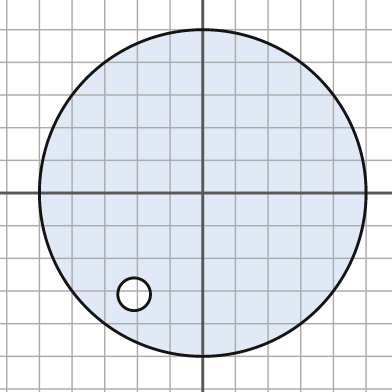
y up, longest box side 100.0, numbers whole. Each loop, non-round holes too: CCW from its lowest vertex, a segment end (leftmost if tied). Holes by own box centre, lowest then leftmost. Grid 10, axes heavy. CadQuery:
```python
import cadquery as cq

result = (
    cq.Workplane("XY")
    .moveTo(0.0, 0.0)
    .circle(50.0)
    .moveTo(-21.0, -31.0)
    .circle(5.0)
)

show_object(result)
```